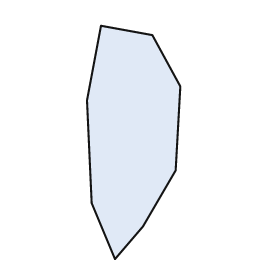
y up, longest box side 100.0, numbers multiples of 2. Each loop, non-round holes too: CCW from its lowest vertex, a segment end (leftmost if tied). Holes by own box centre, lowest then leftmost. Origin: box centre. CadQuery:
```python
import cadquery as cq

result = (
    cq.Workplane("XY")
    .moveTo(-8.0, -50.0)
    .lineTo(4.0, -36.0)
    .lineTo(18.0, -12.0)
    .lineTo(20.0, 24.0)
    .lineTo(8.0, 46.0)
    .lineTo(-14.0, 50.0)
    .lineTo(-20.0, 18.0)
    .lineTo(-18.0, -26.0)
    .close()
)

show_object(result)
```